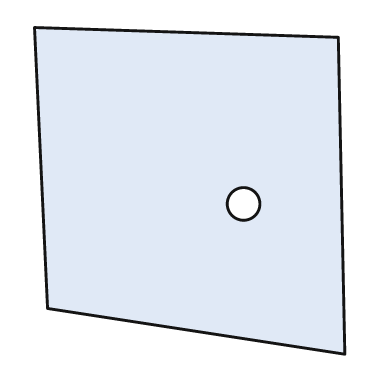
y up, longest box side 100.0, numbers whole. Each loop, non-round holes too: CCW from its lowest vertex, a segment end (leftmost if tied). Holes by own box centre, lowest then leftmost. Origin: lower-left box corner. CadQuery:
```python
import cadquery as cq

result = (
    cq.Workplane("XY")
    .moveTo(95.0, 0.0)
    .lineTo(93.0, 97.0)
    .lineTo(0.0, 100.0)
    .lineTo(4.0, 14.0)
    .close()
    .moveTo(64.0, 46.0)
    .circle(5.0)
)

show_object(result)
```